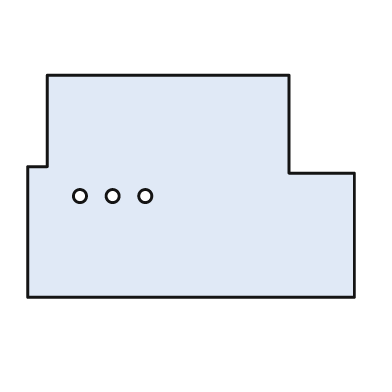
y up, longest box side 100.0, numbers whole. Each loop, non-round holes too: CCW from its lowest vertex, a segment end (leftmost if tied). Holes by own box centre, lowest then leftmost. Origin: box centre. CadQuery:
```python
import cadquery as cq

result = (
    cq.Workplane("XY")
    .moveTo(-50.0, -34.0)
    .lineTo(50.0, -34.0)
    .lineTo(50.0, 4.0)
    .lineTo(30.0, 4.0)
    .lineTo(30.0, 34.0)
    .lineTo(-44.0, 34.0)
    .lineTo(-44.0, 6.0)
    .lineTo(-50.0, 6.0)
    .close()
    .moveTo(-34.0, -3.0)
    .circle(2.0)
    .moveTo(-24.0, -3.0)
    .circle(2.0)
    .moveTo(-14.0, -3.0)
    .circle(2.0)
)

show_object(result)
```